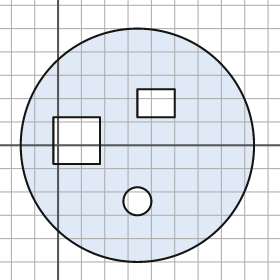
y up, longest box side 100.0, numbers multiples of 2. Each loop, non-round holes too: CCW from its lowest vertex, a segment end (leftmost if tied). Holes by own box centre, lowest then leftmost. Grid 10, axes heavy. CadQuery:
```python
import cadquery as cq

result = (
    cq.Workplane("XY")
    .moveTo(34.0, 0.0)
    .circle(50.0)
    .moveTo(34.0, -24.0)
    .circle(6.0)
    .moveTo(-2.0, -8.0)
    .lineTo(18.0, -8.0)
    .lineTo(18.0, 12.0)
    .lineTo(-2.0, 12.0)
    .close()
    .moveTo(34.0, 12.0)
    .lineTo(50.0, 12.0)
    .lineTo(50.0, 24.0)
    .lineTo(34.0, 24.0)
    .close()
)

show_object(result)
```